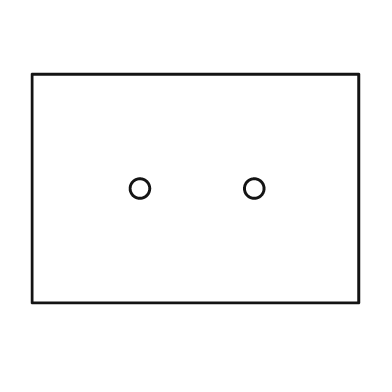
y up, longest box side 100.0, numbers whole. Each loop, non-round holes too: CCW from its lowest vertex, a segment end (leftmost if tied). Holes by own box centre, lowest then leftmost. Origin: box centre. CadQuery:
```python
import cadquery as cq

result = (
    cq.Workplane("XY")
    .moveTo(-50.0, -35.0)
    .lineTo(50.0, -35.0)
    .lineTo(50.0, 35.0)
    .lineTo(-50.0, 35.0)
    .close()
    .moveTo(-17.0, 0.0)
    .circle(3.0)
    .moveTo(18.0, 0.0)
    .circle(3.0)
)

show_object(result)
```